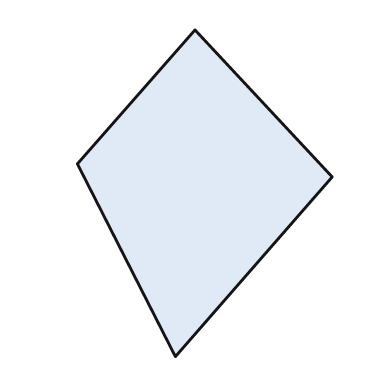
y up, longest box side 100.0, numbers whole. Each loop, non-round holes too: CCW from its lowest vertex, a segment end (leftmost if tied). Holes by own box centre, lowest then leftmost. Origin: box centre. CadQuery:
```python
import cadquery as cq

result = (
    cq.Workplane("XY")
    .moveTo(-9.0, -50.0)
    .lineTo(39.0, 5.0)
    .lineTo(-3.0, 50.0)
    .lineTo(-39.0, 9.0)
    .close()
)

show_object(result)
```